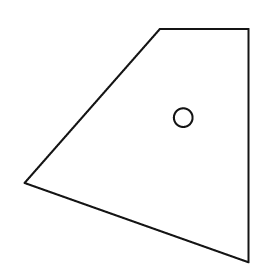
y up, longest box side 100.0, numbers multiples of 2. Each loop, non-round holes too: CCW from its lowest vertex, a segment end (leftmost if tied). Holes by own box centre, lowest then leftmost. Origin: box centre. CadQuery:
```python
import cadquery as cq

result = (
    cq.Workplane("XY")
    .moveTo(48.0, -50.0)
    .lineTo(48.0, 50.0)
    .lineTo(10.0, 50.0)
    .lineTo(-48.0, -16.0)
    .close()
    .moveTo(20.0, 12.0)
    .circle(4.0)
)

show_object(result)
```